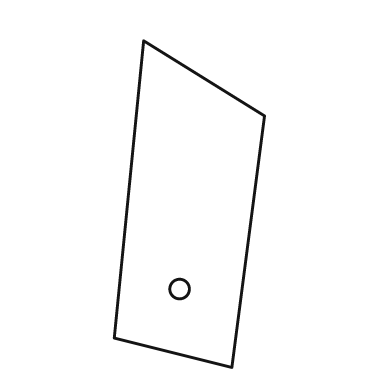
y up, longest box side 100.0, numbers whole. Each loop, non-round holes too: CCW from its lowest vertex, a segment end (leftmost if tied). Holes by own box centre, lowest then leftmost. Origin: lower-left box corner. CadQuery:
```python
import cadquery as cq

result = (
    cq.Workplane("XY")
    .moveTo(36.0, 0.0)
    .lineTo(46.0, 77.0)
    .lineTo(9.0, 100.0)
    .lineTo(0.0, 9.0)
    .close()
    .moveTo(20.0, 24.0)
    .circle(3.0)
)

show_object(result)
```